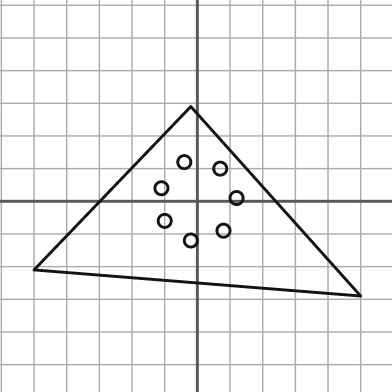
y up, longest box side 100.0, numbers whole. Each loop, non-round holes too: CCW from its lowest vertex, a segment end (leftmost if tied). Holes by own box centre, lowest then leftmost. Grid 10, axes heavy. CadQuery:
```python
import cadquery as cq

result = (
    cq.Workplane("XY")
    .moveTo(50.0, -29.0)
    .lineTo(-2.0, 29.0)
    .lineTo(-50.0, -21.0)
    .close()
    .moveTo(-2.0, -12.0)
    .circle(2.0)
    .moveTo(8.0, -9.0)
    .circle(2.0)
    .moveTo(-10.0, -6.0)
    .circle(2.0)
    .moveTo(12.0, 1.0)
    .circle(2.0)
    .moveTo(-11.0, 4.0)
    .circle(2.0)
    .moveTo(7.0, 10.0)
    .circle(2.0)
    .moveTo(-4.0, 12.0)
    .circle(2.0)
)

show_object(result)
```